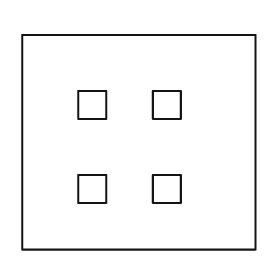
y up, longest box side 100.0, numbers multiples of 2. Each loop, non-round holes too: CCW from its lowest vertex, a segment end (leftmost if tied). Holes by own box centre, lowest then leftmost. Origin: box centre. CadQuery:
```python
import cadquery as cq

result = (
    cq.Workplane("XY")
    .moveTo(-50.0, -46.0)
    .lineTo(50.0, -46.0)
    .lineTo(50.0, 46.0)
    .lineTo(-50.0, 46.0)
    .close()
    .moveTo(-26.0, -26.0)
    .lineTo(-14.0, -26.0)
    .lineTo(-14.0, -14.0)
    .lineTo(-26.0, -14.0)
    .close()
    .moveTo(6.0, -26.0)
    .lineTo(18.0, -26.0)
    .lineTo(18.0, -14.0)
    .lineTo(6.0, -14.0)
    .close()
    .moveTo(-26.0, 10.0)
    .lineTo(-14.0, 10.0)
    .lineTo(-14.0, 22.0)
    .lineTo(-26.0, 22.0)
    .close()
    .moveTo(6.0, 10.0)
    .lineTo(18.0, 10.0)
    .lineTo(18.0, 22.0)
    .lineTo(6.0, 22.0)
    .close()
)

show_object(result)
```